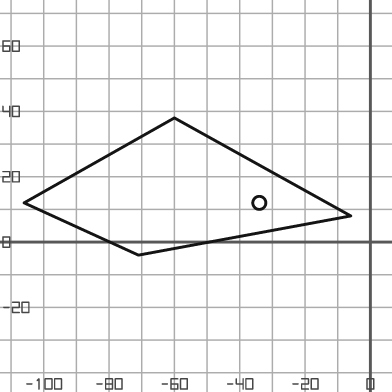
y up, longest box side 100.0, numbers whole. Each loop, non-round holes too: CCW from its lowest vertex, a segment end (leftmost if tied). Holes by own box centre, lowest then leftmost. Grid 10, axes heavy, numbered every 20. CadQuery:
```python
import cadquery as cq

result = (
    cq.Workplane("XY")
    .moveTo(-71.0, -4.0)
    .lineTo(-6.0, 8.0)
    .lineTo(-60.0, 38.0)
    .lineTo(-106.0, 12.0)
    .close()
    .moveTo(-34.0, 12.0)
    .circle(2.0)
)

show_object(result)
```